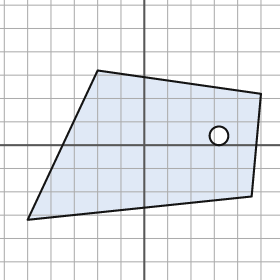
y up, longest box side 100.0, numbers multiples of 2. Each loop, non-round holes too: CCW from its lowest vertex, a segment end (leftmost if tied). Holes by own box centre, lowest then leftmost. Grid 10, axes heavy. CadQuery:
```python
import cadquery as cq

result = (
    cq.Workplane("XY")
    .moveTo(-50.0, -32.0)
    .lineTo(46.0, -22.0)
    .lineTo(50.0, 22.0)
    .lineTo(-20.0, 32.0)
    .close()
    .moveTo(32.0, 4.0)
    .circle(4.0)
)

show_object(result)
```